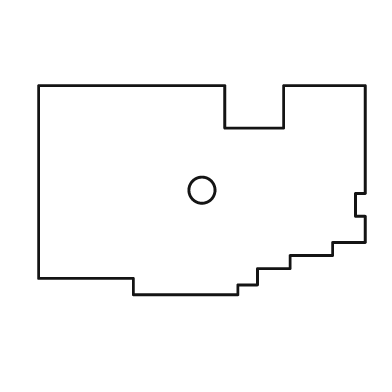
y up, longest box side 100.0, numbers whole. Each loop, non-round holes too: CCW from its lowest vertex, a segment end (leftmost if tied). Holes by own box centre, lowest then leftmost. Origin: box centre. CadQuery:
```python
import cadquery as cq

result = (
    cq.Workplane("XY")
    .moveTo(-21.0, -32.0)
    .lineTo(11.0, -32.0)
    .lineTo(11.0, -29.0)
    .lineTo(17.0, -29.0)
    .lineTo(17.0, -24.0)
    .lineTo(27.0, -24.0)
    .lineTo(27.0, -20.0)
    .lineTo(40.0, -20.0)
    .lineTo(40.0, -16.0)
    .lineTo(50.0, -16.0)
    .lineTo(50.0, -8.0)
    .lineTo(47.0, -8.0)
    .lineTo(47.0, -1.0)
    .lineTo(50.0, -1.0)
    .lineTo(50.0, 32.0)
    .lineTo(25.0, 32.0)
    .lineTo(25.0, 19.0)
    .lineTo(7.0, 19.0)
    .lineTo(7.0, 32.0)
    .lineTo(-50.0, 32.0)
    .lineTo(-50.0, -27.0)
    .lineTo(-21.0, -27.0)
    .close()
    .moveTo(0.0, 0.0)
    .circle(4.0)
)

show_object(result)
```